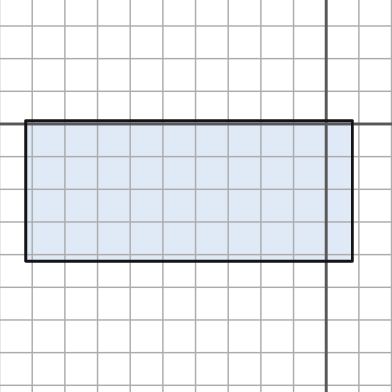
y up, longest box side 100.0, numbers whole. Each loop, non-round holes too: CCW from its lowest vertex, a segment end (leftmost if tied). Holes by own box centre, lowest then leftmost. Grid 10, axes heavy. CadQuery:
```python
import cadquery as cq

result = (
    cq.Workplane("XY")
    .moveTo(-92.0, -42.0)
    .lineTo(8.0, -42.0)
    .lineTo(8.0, 1.0)
    .lineTo(-92.0, 1.0)
    .close()
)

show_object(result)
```